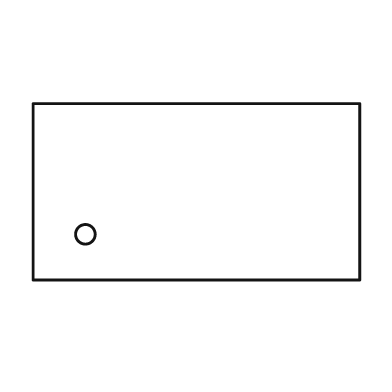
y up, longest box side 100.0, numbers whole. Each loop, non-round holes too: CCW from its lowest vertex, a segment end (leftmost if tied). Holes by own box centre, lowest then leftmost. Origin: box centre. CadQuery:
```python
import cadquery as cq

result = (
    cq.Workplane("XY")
    .moveTo(-50.0, -27.0)
    .lineTo(50.0, -27.0)
    .lineTo(50.0, 27.0)
    .lineTo(-50.0, 27.0)
    .close()
    .moveTo(-34.0, -13.0)
    .circle(3.0)
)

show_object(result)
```